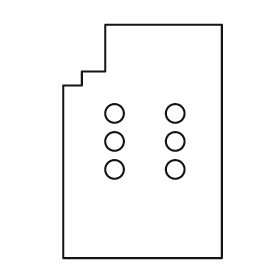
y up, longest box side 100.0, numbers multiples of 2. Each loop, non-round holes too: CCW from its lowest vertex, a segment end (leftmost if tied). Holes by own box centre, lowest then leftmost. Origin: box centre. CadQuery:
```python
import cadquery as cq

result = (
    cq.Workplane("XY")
    .moveTo(-34.0, -50.0)
    .lineTo(34.0, -50.0)
    .lineTo(34.0, 50.0)
    .lineTo(-16.0, 50.0)
    .lineTo(-16.0, 30.0)
    .lineTo(-26.0, 30.0)
    .lineTo(-26.0, 24.0)
    .lineTo(-34.0, 24.0)
    .close()
    .moveTo(-12.0, -12.0)
    .circle(4.0)
    .moveTo(14.0, -12.0)
    .circle(4.0)
    .moveTo(-12.0, 0.0)
    .circle(4.0)
    .moveTo(14.0, 0.0)
    .circle(4.0)
    .moveTo(-12.0, 12.0)
    .circle(4.0)
    .moveTo(14.0, 12.0)
    .circle(4.0)
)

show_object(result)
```